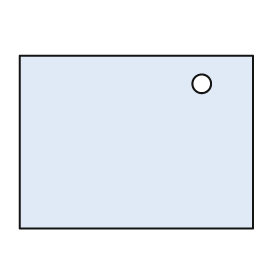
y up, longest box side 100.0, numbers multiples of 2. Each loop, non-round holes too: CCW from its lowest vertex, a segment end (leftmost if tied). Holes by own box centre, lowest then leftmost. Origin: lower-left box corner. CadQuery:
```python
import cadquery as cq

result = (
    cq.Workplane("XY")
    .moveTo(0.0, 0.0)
    .lineTo(100.0, 0.0)
    .lineTo(100.0, 74.0)
    .lineTo(0.0, 74.0)
    .close()
    .moveTo(78.0, 62.0)
    .circle(4.0)
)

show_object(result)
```